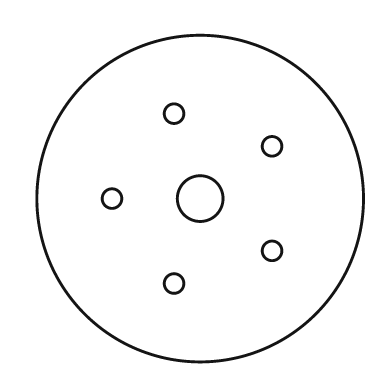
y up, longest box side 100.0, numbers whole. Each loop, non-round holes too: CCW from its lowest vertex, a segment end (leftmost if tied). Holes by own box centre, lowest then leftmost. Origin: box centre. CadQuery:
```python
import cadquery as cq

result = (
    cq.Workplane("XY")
    .moveTo(0.0, 0.0)
    .circle(50.0)
    .moveTo(-8.0, -26.0)
    .circle(3.0)
    .moveTo(22.0, -16.0)
    .circle(3.0)
    .moveTo(-27.0, 0.0)
    .circle(3.0)
    .moveTo(0.0, 0.0)
    .circle(7.0)
    .moveTo(22.0, 16.0)
    .circle(3.0)
    .moveTo(-8.0, 26.0)
    .circle(3.0)
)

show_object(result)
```